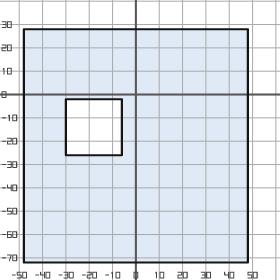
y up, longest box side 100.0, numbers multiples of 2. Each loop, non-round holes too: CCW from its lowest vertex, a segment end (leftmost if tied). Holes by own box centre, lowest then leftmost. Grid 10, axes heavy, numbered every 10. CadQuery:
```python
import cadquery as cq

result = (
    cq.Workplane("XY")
    .moveTo(-48.0, -72.0)
    .lineTo(48.0, -72.0)
    .lineTo(48.0, 28.0)
    .lineTo(-48.0, 28.0)
    .close()
    .moveTo(-30.0, -26.0)
    .lineTo(-6.0, -26.0)
    .lineTo(-6.0, -2.0)
    .lineTo(-30.0, -2.0)
    .close()
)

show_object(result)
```